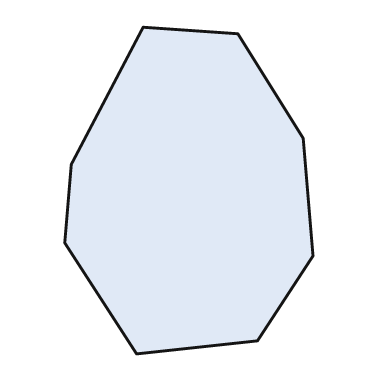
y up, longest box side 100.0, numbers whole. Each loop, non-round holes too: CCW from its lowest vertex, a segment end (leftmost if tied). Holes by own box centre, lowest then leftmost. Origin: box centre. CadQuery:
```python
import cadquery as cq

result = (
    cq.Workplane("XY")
    .moveTo(-16.0, -50.0)
    .lineTo(21.0, -46.0)
    .lineTo(38.0, -20.0)
    .lineTo(35.0, 16.0)
    .lineTo(15.0, 48.0)
    .lineTo(-14.0, 50.0)
    .lineTo(-36.0, 8.0)
    .lineTo(-38.0, -16.0)
    .close()
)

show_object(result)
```